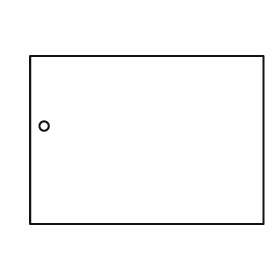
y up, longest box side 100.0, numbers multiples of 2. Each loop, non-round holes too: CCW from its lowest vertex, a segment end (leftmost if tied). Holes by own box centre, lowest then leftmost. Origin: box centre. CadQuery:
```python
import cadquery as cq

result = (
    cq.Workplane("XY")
    .moveTo(-50.0, -36.0)
    .lineTo(50.0, -36.0)
    .lineTo(50.0, 36.0)
    .lineTo(-50.0, 36.0)
    .close()
    .moveTo(-44.0, 6.0)
    .circle(2.0)
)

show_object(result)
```